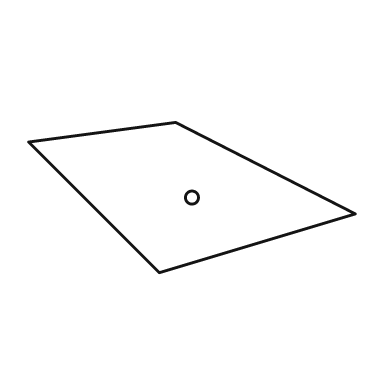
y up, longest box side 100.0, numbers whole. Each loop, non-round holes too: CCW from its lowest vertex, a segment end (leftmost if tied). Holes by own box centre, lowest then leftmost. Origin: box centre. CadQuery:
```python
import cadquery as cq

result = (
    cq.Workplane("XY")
    .moveTo(-10.0, -23.0)
    .lineTo(50.0, -5.0)
    .lineTo(-5.0, 23.0)
    .lineTo(-50.0, 17.0)
    .close()
    .moveTo(0.0, 0.0)
    .circle(2.0)
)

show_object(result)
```